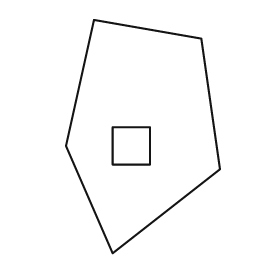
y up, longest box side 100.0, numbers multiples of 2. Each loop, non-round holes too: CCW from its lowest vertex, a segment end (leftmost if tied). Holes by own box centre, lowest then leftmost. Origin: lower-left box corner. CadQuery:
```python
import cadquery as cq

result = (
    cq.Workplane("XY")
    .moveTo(20.0, 0.0)
    .lineTo(66.0, 36.0)
    .lineTo(58.0, 92.0)
    .lineTo(12.0, 100.0)
    .lineTo(0.0, 46.0)
    .close()
    .moveTo(20.0, 38.0)
    .lineTo(36.0, 38.0)
    .lineTo(36.0, 54.0)
    .lineTo(20.0, 54.0)
    .close()
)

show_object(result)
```